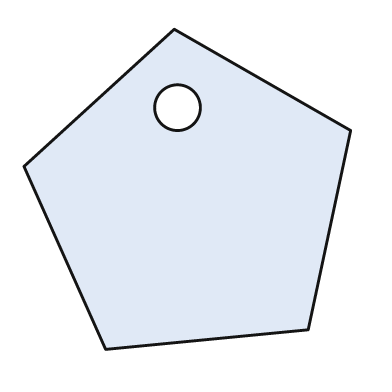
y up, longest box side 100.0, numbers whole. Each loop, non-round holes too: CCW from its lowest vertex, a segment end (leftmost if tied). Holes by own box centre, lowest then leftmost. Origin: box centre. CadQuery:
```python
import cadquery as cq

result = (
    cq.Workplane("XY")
    .moveTo(-25.0, -49.0)
    .lineTo(37.0, -43.0)
    .lineTo(50.0, 18.0)
    .lineTo(-4.0, 49.0)
    .lineTo(-50.0, 7.0)
    .close()
    .moveTo(-3.0, 25.0)
    .circle(7.0)
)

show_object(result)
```